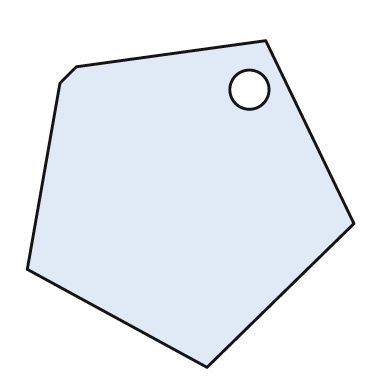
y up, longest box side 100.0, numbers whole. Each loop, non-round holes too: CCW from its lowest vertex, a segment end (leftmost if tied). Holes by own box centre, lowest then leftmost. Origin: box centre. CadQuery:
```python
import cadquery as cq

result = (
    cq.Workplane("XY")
    .moveTo(5.0, -50.0)
    .lineTo(50.0, -6.0)
    .lineTo(23.0, 50.0)
    .lineTo(-35.0, 42.0)
    .lineTo(-40.0, 37.0)
    .lineTo(-50.0, -20.0)
    .close()
    .moveTo(18.0, 35.0)
    .circle(6.0)
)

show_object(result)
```